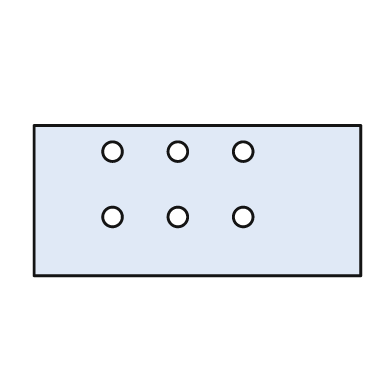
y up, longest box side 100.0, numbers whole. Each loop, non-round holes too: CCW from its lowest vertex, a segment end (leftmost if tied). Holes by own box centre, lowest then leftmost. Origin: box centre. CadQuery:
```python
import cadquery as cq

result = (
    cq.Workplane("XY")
    .moveTo(-50.0, -23.0)
    .lineTo(50.0, -23.0)
    .lineTo(50.0, 23.0)
    .lineTo(-50.0, 23.0)
    .close()
    .moveTo(-26.0, -5.0)
    .circle(3.0)
    .moveTo(-6.0, -5.0)
    .circle(3.0)
    .moveTo(14.0, -5.0)
    .circle(3.0)
    .moveTo(-26.0, 15.0)
    .circle(3.0)
    .moveTo(-6.0, 15.0)
    .circle(3.0)
    .moveTo(14.0, 15.0)
    .circle(3.0)
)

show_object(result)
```